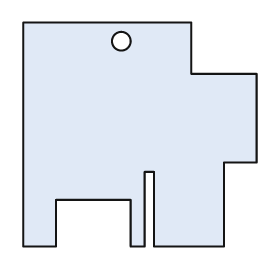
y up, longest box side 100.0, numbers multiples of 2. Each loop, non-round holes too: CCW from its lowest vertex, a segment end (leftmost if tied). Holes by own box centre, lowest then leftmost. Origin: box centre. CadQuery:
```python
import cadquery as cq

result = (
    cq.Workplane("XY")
    .moveTo(-50.0, -48.0)
    .lineTo(-36.0, -48.0)
    .lineTo(-36.0, -28.0)
    .lineTo(-4.0, -28.0)
    .lineTo(-4.0, -48.0)
    .lineTo(2.0, -48.0)
    .lineTo(2.0, -16.0)
    .lineTo(6.0, -16.0)
    .lineTo(6.0, -48.0)
    .lineTo(36.0, -48.0)
    .lineTo(36.0, -12.0)
    .lineTo(50.0, -12.0)
    .lineTo(50.0, 26.0)
    .lineTo(22.0, 26.0)
    .lineTo(22.0, 48.0)
    .lineTo(-50.0, 48.0)
    .close()
    .moveTo(-8.0, 40.0)
    .circle(4.0)
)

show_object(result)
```